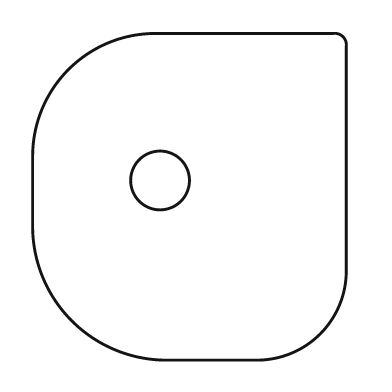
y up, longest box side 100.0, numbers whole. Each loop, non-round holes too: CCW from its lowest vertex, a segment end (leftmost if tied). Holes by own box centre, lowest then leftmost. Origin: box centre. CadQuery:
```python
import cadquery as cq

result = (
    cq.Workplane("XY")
    .moveTo(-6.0, -50.0)
    .lineTo(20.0, -50.0)
    .threePointArc((40.0, -42.0), (48.0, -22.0))
    .lineTo(48.0, 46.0)
    .threePointArc((47.0, 49.0), (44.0, 50.0))
    .lineTo(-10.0, 50.0)
    .threePointArc((-37.0, 39.0), (-48.0, 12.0))
    .lineTo(-48.0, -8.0)
    .threePointArc((-36.0, -38.0), (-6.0, -50.0))
    .close()
    .moveTo(-9.0, 5.0)
    .circle(9.0)
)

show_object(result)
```